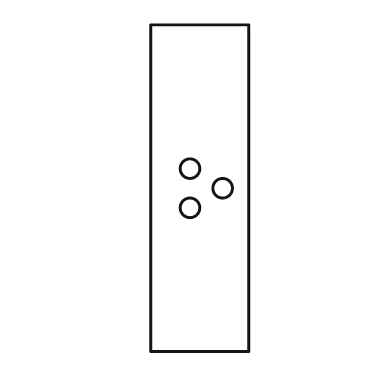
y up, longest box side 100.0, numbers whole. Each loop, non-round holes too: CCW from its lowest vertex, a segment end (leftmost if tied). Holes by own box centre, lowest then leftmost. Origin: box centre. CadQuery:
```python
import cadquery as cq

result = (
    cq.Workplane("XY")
    .moveTo(-15.0, -50.0)
    .lineTo(15.0, -50.0)
    .lineTo(15.0, 50.0)
    .lineTo(-15.0, 50.0)
    .close()
    .moveTo(-3.0, -6.0)
    .circle(3.0)
    .moveTo(7.0, 0.0)
    .circle(3.0)
    .moveTo(-3.0, 6.0)
    .circle(3.0)
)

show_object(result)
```